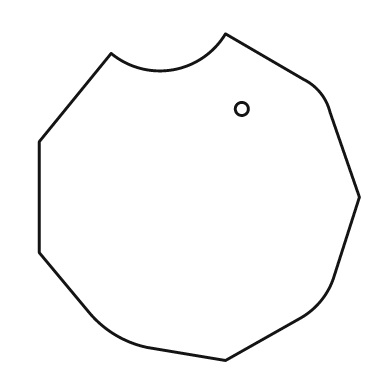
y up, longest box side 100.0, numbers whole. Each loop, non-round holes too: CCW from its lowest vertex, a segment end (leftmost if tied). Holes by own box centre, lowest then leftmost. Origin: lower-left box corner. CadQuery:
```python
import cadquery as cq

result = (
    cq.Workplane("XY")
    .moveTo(57.0, 0.0)
    .lineTo(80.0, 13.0)
    .threePointArc((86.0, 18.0), (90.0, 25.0))
    .lineTo(98.0, 50.0)
    .lineTo(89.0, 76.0)
    .threePointArc((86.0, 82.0), (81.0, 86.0))
    .lineTo(57.0, 100.0)
    .threePointArc((41.0, 89.0), (22.0, 94.0))
    .lineTo(0.0, 67.0)
    .lineTo(0.0, 33.0)
    .lineTo(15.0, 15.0)
    .threePointArc((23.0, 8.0), (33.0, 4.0))
    .close()
    .moveTo(62.0, 77.0)
    .circle(2.0)
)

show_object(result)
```